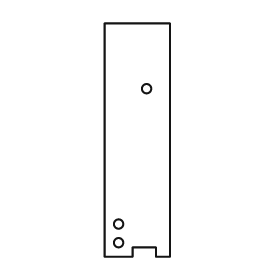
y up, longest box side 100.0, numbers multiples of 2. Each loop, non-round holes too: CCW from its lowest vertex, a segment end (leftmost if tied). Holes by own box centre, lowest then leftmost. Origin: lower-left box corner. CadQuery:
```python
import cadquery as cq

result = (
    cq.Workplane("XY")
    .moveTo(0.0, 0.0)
    .lineTo(12.0, 0.0)
    .lineTo(12.0, 4.0)
    .lineTo(22.0, 4.0)
    .lineTo(22.0, 0.0)
    .lineTo(28.0, 0.0)
    .lineTo(28.0, 100.0)
    .lineTo(0.0, 100.0)
    .close()
    .moveTo(6.0, 6.0)
    .circle(2.0)
    .moveTo(6.0, 14.0)
    .circle(2.0)
    .moveTo(18.0, 72.0)
    .circle(2.0)
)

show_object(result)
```